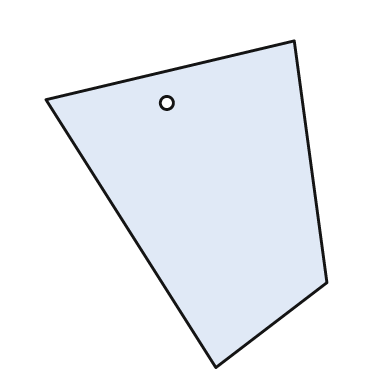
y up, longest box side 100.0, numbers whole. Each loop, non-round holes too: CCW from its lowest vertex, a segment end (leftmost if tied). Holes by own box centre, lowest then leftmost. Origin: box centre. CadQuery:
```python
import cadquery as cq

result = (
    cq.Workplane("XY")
    .moveTo(9.0, -50.0)
    .lineTo(43.0, -24.0)
    .lineTo(33.0, 50.0)
    .lineTo(-43.0, 32.0)
    .close()
    .moveTo(-6.0, 31.0)
    .circle(2.0)
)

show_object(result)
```